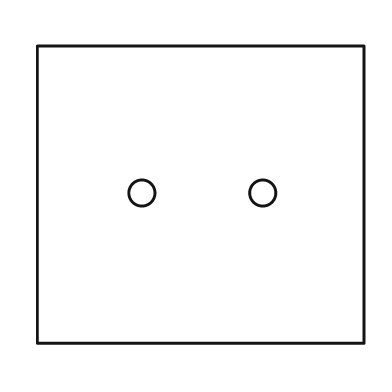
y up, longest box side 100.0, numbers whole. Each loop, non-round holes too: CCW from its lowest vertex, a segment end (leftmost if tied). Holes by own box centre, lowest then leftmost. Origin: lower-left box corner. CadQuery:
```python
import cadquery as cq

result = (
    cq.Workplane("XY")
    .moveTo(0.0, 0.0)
    .lineTo(100.0, 0.0)
    .lineTo(100.0, 91.0)
    .lineTo(0.0, 91.0)
    .close()
    .moveTo(32.0, 46.0)
    .circle(4.0)
    .moveTo(69.0, 46.0)
    .circle(4.0)
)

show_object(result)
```